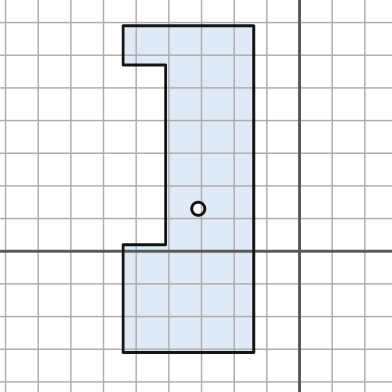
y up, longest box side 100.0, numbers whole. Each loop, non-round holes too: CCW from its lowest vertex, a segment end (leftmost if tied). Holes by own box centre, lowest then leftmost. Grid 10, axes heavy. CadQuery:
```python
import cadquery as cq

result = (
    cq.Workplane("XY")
    .moveTo(-54.0, -31.0)
    .lineTo(-14.0, -31.0)
    .lineTo(-14.0, 69.0)
    .lineTo(-54.0, 69.0)
    .lineTo(-54.0, 57.0)
    .lineTo(-41.0, 57.0)
    .lineTo(-41.0, 2.0)
    .lineTo(-54.0, 2.0)
    .close()
    .moveTo(-31.0, 13.0)
    .circle(2.0)
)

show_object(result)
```